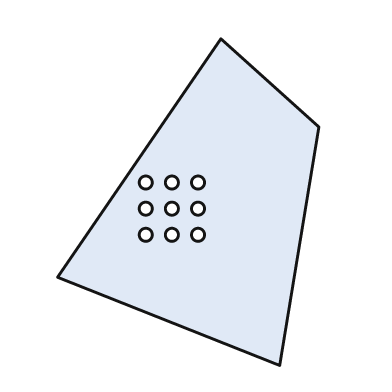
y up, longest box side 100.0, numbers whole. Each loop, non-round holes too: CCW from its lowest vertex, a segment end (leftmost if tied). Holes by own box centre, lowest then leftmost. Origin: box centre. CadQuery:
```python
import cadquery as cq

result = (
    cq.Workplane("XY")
    .moveTo(28.0, -50.0)
    .lineTo(40.0, 23.0)
    .lineTo(10.0, 50.0)
    .lineTo(-40.0, -23.0)
    .close()
    .moveTo(-13.0, -10.0)
    .circle(2.0)
    .moveTo(-5.0, -10.0)
    .circle(2.0)
    .moveTo(3.0, -10.0)
    .circle(2.0)
    .moveTo(-13.0, -2.0)
    .circle(2.0)
    .moveTo(-5.0, -2.0)
    .circle(2.0)
    .moveTo(3.0, -2.0)
    .circle(2.0)
    .moveTo(-13.0, 6.0)
    .circle(2.0)
    .moveTo(-5.0, 6.0)
    .circle(2.0)
    .moveTo(3.0, 6.0)
    .circle(2.0)
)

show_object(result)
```